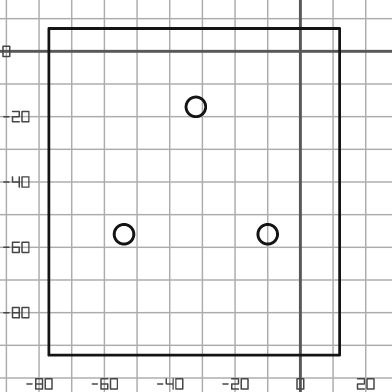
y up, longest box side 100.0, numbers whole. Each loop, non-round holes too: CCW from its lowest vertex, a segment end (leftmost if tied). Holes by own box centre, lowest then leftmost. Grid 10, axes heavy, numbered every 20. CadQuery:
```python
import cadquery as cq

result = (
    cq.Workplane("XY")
    .moveTo(-77.0, -93.0)
    .lineTo(12.0, -93.0)
    .lineTo(12.0, 7.0)
    .lineTo(-77.0, 7.0)
    .close()
    .moveTo(-54.0, -56.0)
    .circle(3.0)
    .moveTo(-10.0, -56.0)
    .circle(3.0)
    .moveTo(-32.0, -17.0)
    .circle(3.0)
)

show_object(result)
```